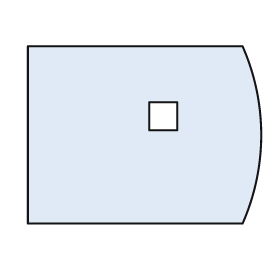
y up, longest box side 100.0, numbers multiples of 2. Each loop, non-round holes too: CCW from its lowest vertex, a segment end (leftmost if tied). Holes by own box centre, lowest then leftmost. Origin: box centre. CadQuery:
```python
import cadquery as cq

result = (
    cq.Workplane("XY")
    .moveTo(-50.0, -38.0)
    .lineTo(42.0, -38.0)
    .threePointArc((50.0, 0.0), (42.0, 38.0))
    .lineTo(-50.0, 38.0)
    .close()
    .moveTo(2.0, 2.0)
    .lineTo(14.0, 2.0)
    .lineTo(14.0, 14.0)
    .lineTo(2.0, 14.0)
    .close()
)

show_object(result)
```